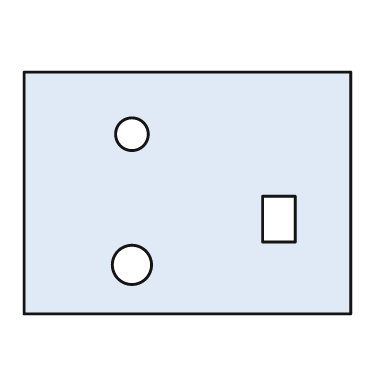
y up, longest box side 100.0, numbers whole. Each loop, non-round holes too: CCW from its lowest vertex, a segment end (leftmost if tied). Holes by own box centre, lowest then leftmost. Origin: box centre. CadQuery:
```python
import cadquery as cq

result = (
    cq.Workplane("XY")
    .moveTo(-50.0, -37.0)
    .lineTo(50.0, -37.0)
    .lineTo(50.0, 37.0)
    .lineTo(-50.0, 37.0)
    .close()
    .moveTo(-17.0, -22.0)
    .circle(6.0)
    .moveTo(23.0, -15.0)
    .lineTo(33.0, -15.0)
    .lineTo(33.0, -1.0)
    .lineTo(23.0, -1.0)
    .close()
    .moveTo(-17.0, 18.0)
    .circle(5.0)
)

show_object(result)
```